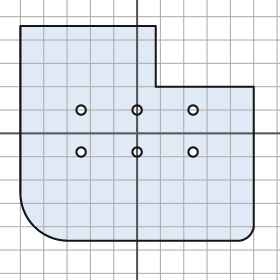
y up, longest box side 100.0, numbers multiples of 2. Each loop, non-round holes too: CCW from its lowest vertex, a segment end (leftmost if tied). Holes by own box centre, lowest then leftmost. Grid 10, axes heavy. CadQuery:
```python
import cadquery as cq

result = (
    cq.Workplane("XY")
    .moveTo(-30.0, -46.0)
    .lineTo(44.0, -46.0)
    .threePointArc((48.0, -44.0), (50.0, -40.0))
    .lineTo(50.0, 20.0)
    .lineTo(8.0, 20.0)
    .lineTo(8.0, 46.0)
    .lineTo(-50.0, 46.0)
    .lineTo(-50.0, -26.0)
    .threePointArc((-44.0, -40.0), (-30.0, -46.0))
    .close()
    .moveTo(-24.0, -8.0)
    .circle(2.0)
    .moveTo(0.0, -8.0)
    .circle(2.0)
    .moveTo(24.0, -8.0)
    .circle(2.0)
    .moveTo(-24.0, 10.0)
    .circle(2.0)
    .moveTo(0.0, 10.0)
    .circle(2.0)
    .moveTo(24.0, 10.0)
    .circle(2.0)
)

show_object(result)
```